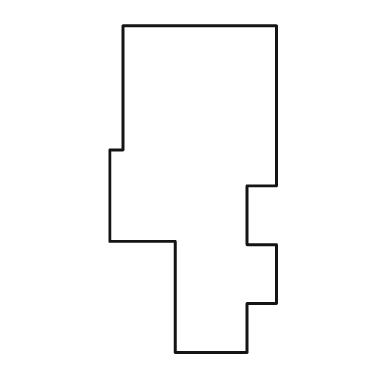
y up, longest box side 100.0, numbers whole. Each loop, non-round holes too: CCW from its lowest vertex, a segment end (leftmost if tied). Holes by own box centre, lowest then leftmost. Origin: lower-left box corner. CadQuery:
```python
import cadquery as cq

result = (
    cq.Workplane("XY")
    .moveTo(20.0, 0.0)
    .lineTo(42.0, 0.0)
    .lineTo(42.0, 15.0)
    .lineTo(51.0, 15.0)
    .lineTo(51.0, 33.0)
    .lineTo(42.0, 33.0)
    .lineTo(42.0, 51.0)
    .lineTo(51.0, 51.0)
    .lineTo(51.0, 100.0)
    .lineTo(4.0, 100.0)
    .lineTo(4.0, 62.0)
    .lineTo(0.0, 62.0)
    .lineTo(0.0, 34.0)
    .lineTo(20.0, 34.0)
    .close()
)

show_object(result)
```